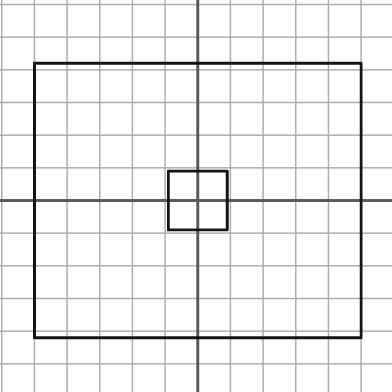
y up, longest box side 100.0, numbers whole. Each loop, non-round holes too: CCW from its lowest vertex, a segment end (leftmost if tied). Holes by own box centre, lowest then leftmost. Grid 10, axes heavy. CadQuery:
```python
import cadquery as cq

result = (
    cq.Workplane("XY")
    .moveTo(-50.0, -42.0)
    .lineTo(50.0, -42.0)
    .lineTo(50.0, 42.0)
    .lineTo(-50.0, 42.0)
    .close()
    .moveTo(-9.0, -9.0)
    .lineTo(9.0, -9.0)
    .lineTo(9.0, 9.0)
    .lineTo(-9.0, 9.0)
    .close()
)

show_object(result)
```